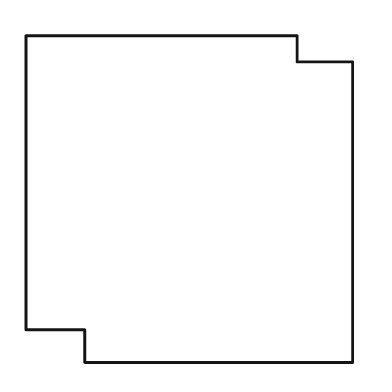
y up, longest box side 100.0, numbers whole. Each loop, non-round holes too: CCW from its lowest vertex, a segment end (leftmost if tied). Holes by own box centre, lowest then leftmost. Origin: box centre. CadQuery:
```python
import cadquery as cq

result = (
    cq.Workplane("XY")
    .moveTo(-32.0, -50.0)
    .lineTo(50.0, -50.0)
    .lineTo(50.0, 42.0)
    .lineTo(33.0, 42.0)
    .lineTo(33.0, 50.0)
    .lineTo(-50.0, 50.0)
    .lineTo(-50.0, -40.0)
    .lineTo(-32.0, -40.0)
    .close()
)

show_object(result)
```